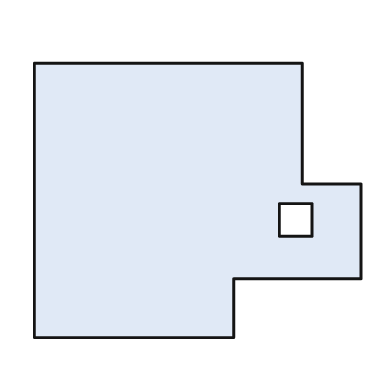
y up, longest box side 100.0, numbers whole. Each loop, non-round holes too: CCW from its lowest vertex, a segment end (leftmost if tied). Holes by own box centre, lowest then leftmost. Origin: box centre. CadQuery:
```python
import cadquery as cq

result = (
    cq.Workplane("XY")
    .moveTo(-50.0, -42.0)
    .lineTo(11.0, -42.0)
    .lineTo(11.0, -24.0)
    .lineTo(50.0, -24.0)
    .lineTo(50.0, 5.0)
    .lineTo(32.0, 5.0)
    .lineTo(32.0, 42.0)
    .lineTo(-50.0, 42.0)
    .close()
    .moveTo(25.0, -11.0)
    .lineTo(35.0, -11.0)
    .lineTo(35.0, -1.0)
    .lineTo(25.0, -1.0)
    .close()
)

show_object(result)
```